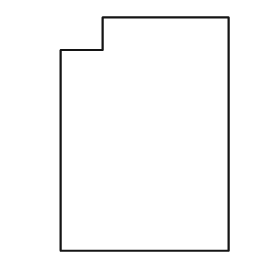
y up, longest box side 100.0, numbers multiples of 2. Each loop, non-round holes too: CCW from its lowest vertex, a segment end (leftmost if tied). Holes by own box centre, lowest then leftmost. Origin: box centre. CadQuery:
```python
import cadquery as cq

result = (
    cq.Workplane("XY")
    .moveTo(-36.0, -50.0)
    .lineTo(36.0, -50.0)
    .lineTo(36.0, 50.0)
    .lineTo(-18.0, 50.0)
    .lineTo(-18.0, 36.0)
    .lineTo(-36.0, 36.0)
    .close()
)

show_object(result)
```